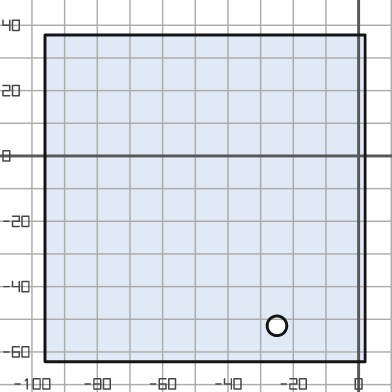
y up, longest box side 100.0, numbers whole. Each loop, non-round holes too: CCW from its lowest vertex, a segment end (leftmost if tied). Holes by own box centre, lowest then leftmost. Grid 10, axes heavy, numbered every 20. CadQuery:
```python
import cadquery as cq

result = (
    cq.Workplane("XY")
    .moveTo(-96.0, -63.0)
    .lineTo(2.0, -63.0)
    .lineTo(2.0, 37.0)
    .lineTo(-96.0, 37.0)
    .close()
    .moveTo(-25.0, -52.0)
    .circle(3.0)
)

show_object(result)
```